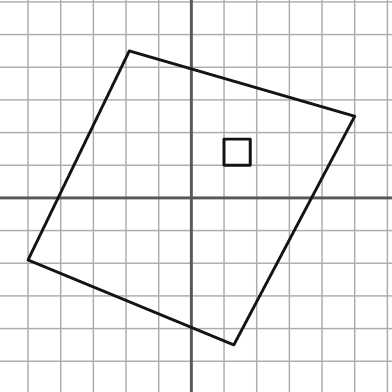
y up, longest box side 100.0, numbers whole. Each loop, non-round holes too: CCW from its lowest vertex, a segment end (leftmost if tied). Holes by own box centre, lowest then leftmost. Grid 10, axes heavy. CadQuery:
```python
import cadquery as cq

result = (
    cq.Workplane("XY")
    .moveTo(13.0, -45.0)
    .lineTo(50.0, 25.0)
    .lineTo(-19.0, 45.0)
    .lineTo(-50.0, -19.0)
    .close()
    .moveTo(10.0, 10.0)
    .lineTo(18.0, 10.0)
    .lineTo(18.0, 18.0)
    .lineTo(10.0, 18.0)
    .close()
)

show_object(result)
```